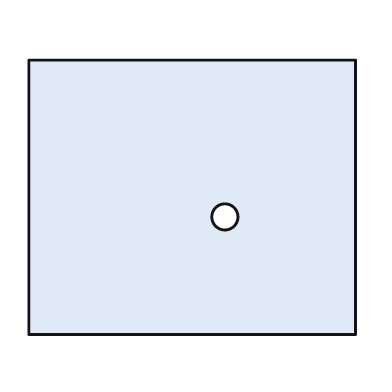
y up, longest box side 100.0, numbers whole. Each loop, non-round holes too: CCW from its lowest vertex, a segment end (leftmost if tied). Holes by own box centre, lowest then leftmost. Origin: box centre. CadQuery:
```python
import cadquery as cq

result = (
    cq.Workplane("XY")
    .moveTo(-50.0, -42.0)
    .lineTo(50.0, -42.0)
    .lineTo(50.0, 42.0)
    .lineTo(-50.0, 42.0)
    .close()
    .moveTo(10.0, -6.0)
    .circle(4.0)
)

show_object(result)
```